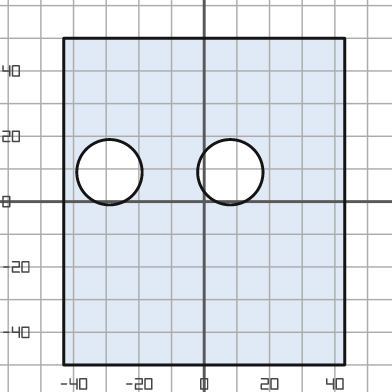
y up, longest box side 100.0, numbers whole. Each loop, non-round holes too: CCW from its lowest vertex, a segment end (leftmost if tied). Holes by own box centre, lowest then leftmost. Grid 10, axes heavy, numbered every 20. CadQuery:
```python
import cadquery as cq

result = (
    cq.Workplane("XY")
    .moveTo(-43.0, -50.0)
    .lineTo(43.0, -50.0)
    .lineTo(43.0, 50.0)
    .lineTo(-43.0, 50.0)
    .close()
    .moveTo(-29.0, 9.0)
    .circle(10.0)
    .moveTo(8.0, 9.0)
    .circle(10.0)
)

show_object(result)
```